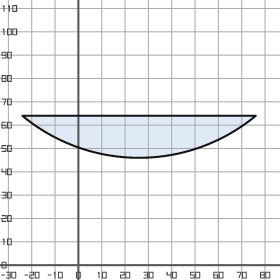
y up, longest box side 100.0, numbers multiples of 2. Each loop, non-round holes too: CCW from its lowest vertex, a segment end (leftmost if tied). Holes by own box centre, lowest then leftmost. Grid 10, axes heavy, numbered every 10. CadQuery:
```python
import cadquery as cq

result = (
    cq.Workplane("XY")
    .moveTo(-24.0, 64.0)
    .threePointArc((26.0, 46.0), (76.0, 64.0))
    .close()
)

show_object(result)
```